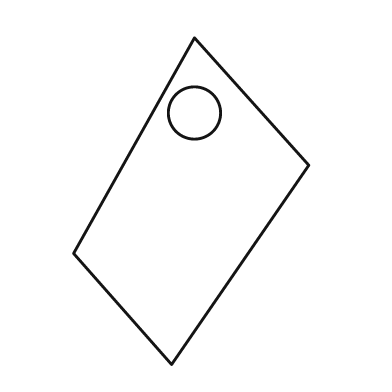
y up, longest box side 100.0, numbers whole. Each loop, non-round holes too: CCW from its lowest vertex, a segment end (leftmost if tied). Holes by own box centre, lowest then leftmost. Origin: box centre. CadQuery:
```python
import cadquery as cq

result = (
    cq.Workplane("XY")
    .moveTo(-6.0, -50.0)
    .lineTo(36.0, 11.0)
    .lineTo(1.0, 50.0)
    .lineTo(-36.0, -16.0)
    .close()
    .moveTo(1.0, 27.0)
    .circle(8.0)
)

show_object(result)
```